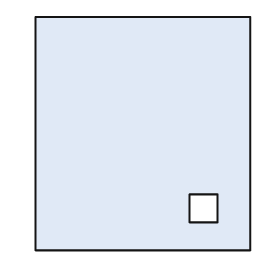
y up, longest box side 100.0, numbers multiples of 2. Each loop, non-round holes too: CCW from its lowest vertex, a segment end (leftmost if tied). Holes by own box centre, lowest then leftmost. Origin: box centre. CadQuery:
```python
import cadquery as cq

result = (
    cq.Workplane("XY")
    .moveTo(-46.0, -50.0)
    .lineTo(46.0, -50.0)
    .lineTo(46.0, 50.0)
    .lineTo(-46.0, 50.0)
    .close()
    .moveTo(20.0, -38.0)
    .lineTo(32.0, -38.0)
    .lineTo(32.0, -26.0)
    .lineTo(20.0, -26.0)
    .close()
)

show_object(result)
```